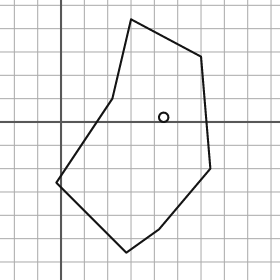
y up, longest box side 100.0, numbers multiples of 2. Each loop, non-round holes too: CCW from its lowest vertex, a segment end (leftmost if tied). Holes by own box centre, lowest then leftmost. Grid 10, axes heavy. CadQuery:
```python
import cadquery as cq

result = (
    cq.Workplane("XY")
    .moveTo(28.0, -56.0)
    .lineTo(42.0, -46.0)
    .lineTo(64.0, -20.0)
    .lineTo(60.0, 28.0)
    .lineTo(30.0, 44.0)
    .lineTo(22.0, 10.0)
    .lineTo(-2.0, -26.0)
    .close()
    .moveTo(44.0, 2.0)
    .circle(2.0)
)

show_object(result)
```